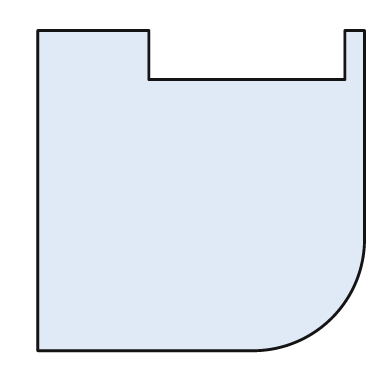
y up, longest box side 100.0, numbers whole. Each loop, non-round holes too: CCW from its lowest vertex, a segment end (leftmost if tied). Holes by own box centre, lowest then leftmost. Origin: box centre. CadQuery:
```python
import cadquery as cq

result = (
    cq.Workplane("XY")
    .moveTo(-50.0, -49.0)
    .lineTo(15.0, -49.0)
    .threePointArc((40.0, -39.0), (50.0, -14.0))
    .lineTo(50.0, 49.0)
    .lineTo(44.0, 49.0)
    .lineTo(44.0, 34.0)
    .lineTo(-16.0, 34.0)
    .lineTo(-16.0, 49.0)
    .lineTo(-50.0, 49.0)
    .close()
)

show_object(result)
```